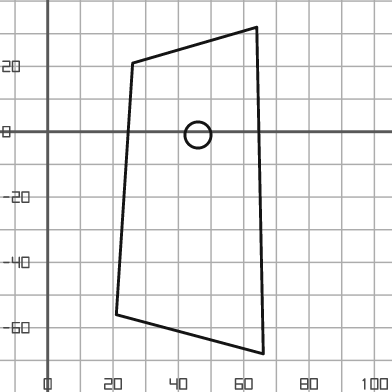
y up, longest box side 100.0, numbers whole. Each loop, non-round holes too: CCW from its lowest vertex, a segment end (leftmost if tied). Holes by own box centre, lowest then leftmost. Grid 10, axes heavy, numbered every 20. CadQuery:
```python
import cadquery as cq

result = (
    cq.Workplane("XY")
    .moveTo(66.0, -68.0)
    .lineTo(64.0, 32.0)
    .lineTo(26.0, 21.0)
    .lineTo(21.0, -56.0)
    .close()
    .moveTo(46.0, -1.0)
    .circle(4.0)
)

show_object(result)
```